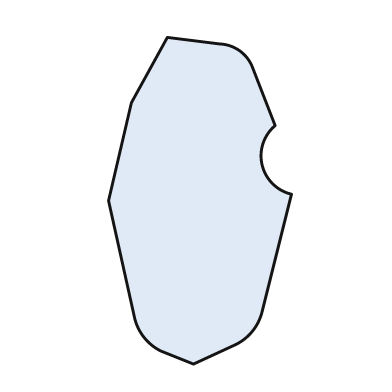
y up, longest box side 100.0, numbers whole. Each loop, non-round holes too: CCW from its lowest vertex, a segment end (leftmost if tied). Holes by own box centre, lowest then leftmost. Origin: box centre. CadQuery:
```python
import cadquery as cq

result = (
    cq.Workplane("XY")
    .moveTo(-2.0, -50.0)
    .lineTo(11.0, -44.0)
    .threePointArc((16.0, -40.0), (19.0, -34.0))
    .lineTo(28.0, 2.0)
    .threePointArc((19.0, 11.0), (23.0, 23.0))
    .lineTo(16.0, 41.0)
    .threePointArc((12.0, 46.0), (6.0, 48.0))
    .lineTo(-10.0, 50.0)
    .lineTo(-21.0, 30.0)
    .lineTo(-28.0, 0.0)
    .lineTo(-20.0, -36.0)
    .threePointArc((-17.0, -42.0), (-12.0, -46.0))
    .close()
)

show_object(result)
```